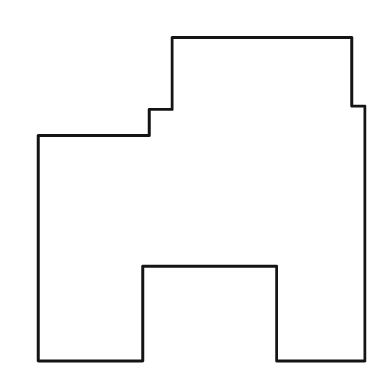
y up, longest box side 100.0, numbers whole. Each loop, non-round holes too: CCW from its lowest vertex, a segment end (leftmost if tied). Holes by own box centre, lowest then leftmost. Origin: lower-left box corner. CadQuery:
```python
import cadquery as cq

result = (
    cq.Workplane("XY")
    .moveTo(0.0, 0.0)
    .lineTo(32.0, 0.0)
    .lineTo(32.0, 29.0)
    .lineTo(73.0, 29.0)
    .lineTo(73.0, 0.0)
    .lineTo(100.0, 0.0)
    .lineTo(100.0, 78.0)
    .lineTo(96.0, 78.0)
    .lineTo(96.0, 99.0)
    .lineTo(41.0, 99.0)
    .lineTo(41.0, 77.0)
    .lineTo(34.0, 77.0)
    .lineTo(34.0, 69.0)
    .lineTo(0.0, 69.0)
    .close()
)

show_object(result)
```